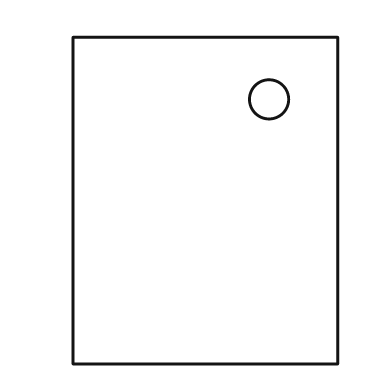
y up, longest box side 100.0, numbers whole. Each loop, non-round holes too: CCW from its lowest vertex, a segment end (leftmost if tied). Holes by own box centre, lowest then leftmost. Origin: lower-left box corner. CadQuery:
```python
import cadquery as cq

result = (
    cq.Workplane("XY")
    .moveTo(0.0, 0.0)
    .lineTo(81.0, 0.0)
    .lineTo(81.0, 100.0)
    .lineTo(0.0, 100.0)
    .close()
    .moveTo(60.0, 81.0)
    .circle(6.0)
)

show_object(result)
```